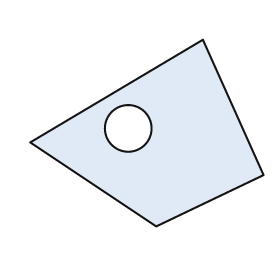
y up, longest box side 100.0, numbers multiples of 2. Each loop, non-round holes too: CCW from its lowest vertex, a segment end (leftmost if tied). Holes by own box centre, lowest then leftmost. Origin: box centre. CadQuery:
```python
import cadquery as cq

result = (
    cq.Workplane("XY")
    .moveTo(4.0, -40.0)
    .lineTo(50.0, -18.0)
    .lineTo(24.0, 40.0)
    .lineTo(-50.0, -4.0)
    .close()
    .moveTo(-8.0, 2.0)
    .circle(10.0)
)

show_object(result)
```